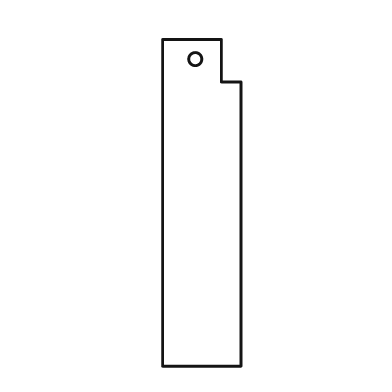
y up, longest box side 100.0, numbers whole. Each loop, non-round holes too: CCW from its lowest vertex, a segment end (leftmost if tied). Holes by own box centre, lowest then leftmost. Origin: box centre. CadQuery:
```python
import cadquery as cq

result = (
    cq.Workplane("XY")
    .moveTo(-12.0, -50.0)
    .lineTo(12.0, -50.0)
    .lineTo(12.0, 37.0)
    .lineTo(6.0, 37.0)
    .lineTo(6.0, 50.0)
    .lineTo(-12.0, 50.0)
    .close()
    .moveTo(-2.0, 44.0)
    .circle(2.0)
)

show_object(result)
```